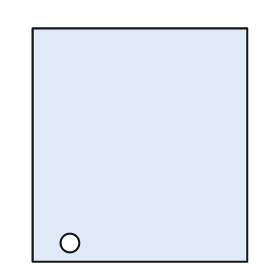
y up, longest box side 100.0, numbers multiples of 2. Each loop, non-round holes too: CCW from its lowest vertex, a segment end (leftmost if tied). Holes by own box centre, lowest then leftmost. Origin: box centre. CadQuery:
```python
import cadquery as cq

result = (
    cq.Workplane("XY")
    .moveTo(-46.0, -50.0)
    .lineTo(46.0, -50.0)
    .lineTo(46.0, 50.0)
    .lineTo(-46.0, 50.0)
    .close()
    .moveTo(-30.0, -42.0)
    .circle(4.0)
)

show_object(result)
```